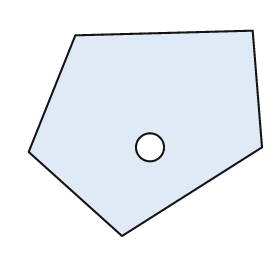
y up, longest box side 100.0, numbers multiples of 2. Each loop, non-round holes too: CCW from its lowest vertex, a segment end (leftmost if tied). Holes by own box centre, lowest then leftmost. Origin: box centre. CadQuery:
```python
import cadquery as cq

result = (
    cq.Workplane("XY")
    .moveTo(-10.0, -44.0)
    .lineTo(50.0, -6.0)
    .lineTo(46.0, 44.0)
    .lineTo(-30.0, 42.0)
    .lineTo(-50.0, -8.0)
    .close()
    .moveTo(2.0, -6.0)
    .circle(6.0)
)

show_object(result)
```